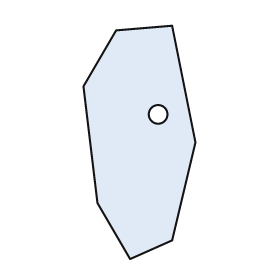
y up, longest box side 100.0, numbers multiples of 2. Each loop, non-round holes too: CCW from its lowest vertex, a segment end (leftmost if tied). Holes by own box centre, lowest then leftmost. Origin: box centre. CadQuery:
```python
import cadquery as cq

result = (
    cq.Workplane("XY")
    .moveTo(-4.0, -50.0)
    .lineTo(14.0, -42.0)
    .lineTo(24.0, 0.0)
    .lineTo(14.0, 50.0)
    .lineTo(-10.0, 48.0)
    .lineTo(-24.0, 24.0)
    .lineTo(-18.0, -26.0)
    .close()
    .moveTo(8.0, 12.0)
    .circle(4.0)
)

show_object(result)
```